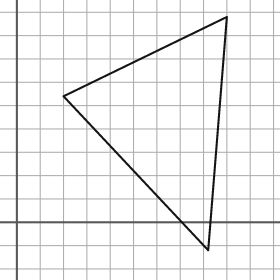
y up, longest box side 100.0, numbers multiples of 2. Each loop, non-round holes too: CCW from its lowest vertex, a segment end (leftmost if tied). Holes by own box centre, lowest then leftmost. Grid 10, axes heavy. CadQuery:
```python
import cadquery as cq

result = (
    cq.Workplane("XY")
    .moveTo(82.0, -12.0)
    .lineTo(90.0, 88.0)
    .lineTo(20.0, 54.0)
    .close()
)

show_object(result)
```